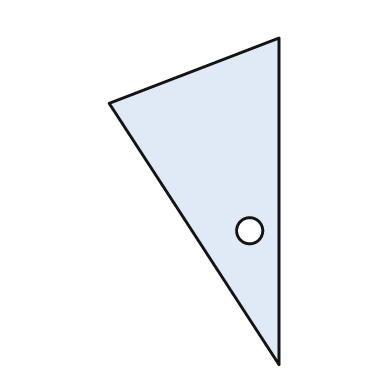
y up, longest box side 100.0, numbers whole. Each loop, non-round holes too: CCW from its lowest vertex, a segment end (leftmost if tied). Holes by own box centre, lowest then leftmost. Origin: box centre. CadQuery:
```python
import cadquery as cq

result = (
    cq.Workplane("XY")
    .moveTo(26.0, -50.0)
    .lineTo(26.0, 50.0)
    .lineTo(-26.0, 30.0)
    .close()
    .moveTo(17.0, -9.0)
    .circle(4.0)
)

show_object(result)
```